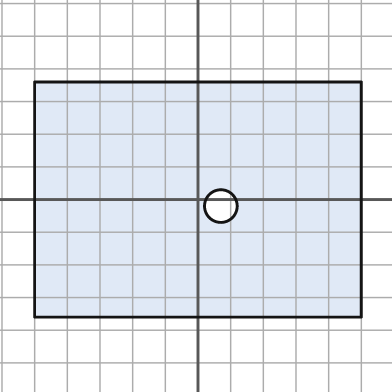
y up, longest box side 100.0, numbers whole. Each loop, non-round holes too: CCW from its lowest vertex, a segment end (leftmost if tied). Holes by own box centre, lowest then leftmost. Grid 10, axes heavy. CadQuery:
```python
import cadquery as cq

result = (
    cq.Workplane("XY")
    .moveTo(-50.0, -36.0)
    .lineTo(50.0, -36.0)
    .lineTo(50.0, 36.0)
    .lineTo(-50.0, 36.0)
    .close()
    .moveTo(7.0, -2.0)
    .circle(5.0)
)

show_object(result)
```